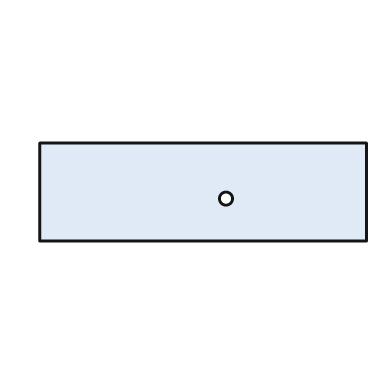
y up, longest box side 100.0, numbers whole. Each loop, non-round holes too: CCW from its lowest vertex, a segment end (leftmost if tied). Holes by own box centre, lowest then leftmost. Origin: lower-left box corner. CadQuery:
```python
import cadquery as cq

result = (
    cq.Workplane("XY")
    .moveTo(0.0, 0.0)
    .lineTo(100.0, 0.0)
    .lineTo(100.0, 30.0)
    .lineTo(0.0, 30.0)
    .close()
    .moveTo(57.0, 13.0)
    .circle(2.0)
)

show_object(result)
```